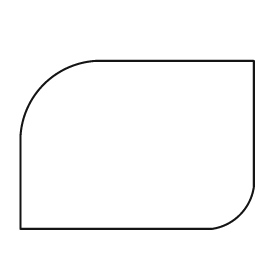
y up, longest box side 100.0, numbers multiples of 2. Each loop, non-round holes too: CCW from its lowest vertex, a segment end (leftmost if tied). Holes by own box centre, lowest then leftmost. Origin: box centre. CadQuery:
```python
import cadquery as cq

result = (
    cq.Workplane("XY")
    .moveTo(-50.0, -36.0)
    .lineTo(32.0, -36.0)
    .threePointArc((44.0, -30.0), (50.0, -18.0))
    .lineTo(50.0, 36.0)
    .lineTo(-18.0, 36.0)
    .threePointArc((-40.0, 26.0), (-50.0, 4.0))
    .close()
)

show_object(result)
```